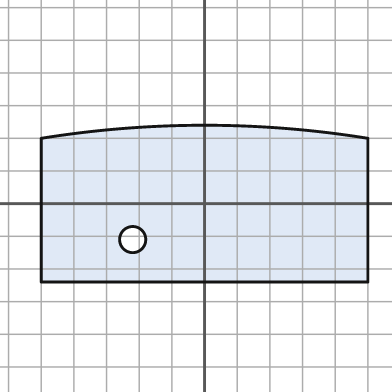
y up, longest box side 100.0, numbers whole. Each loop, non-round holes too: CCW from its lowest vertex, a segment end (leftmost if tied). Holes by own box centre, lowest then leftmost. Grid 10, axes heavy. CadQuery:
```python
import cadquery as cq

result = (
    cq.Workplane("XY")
    .moveTo(-50.0, -24.0)
    .lineTo(50.0, -24.0)
    .lineTo(50.0, 20.0)
    .threePointArc((0.0, 24.0), (-50.0, 20.0))
    .close()
    .moveTo(-22.0, -11.0)
    .circle(4.0)
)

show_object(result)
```